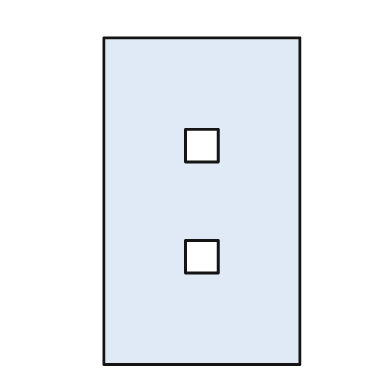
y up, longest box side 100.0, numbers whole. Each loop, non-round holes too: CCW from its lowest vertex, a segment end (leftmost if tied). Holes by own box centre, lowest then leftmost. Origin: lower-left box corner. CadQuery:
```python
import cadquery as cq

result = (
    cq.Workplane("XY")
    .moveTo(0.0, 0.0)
    .lineTo(60.0, 0.0)
    .lineTo(60.0, 100.0)
    .lineTo(0.0, 100.0)
    .close()
    .moveTo(25.0, 28.0)
    .lineTo(35.0, 28.0)
    .lineTo(35.0, 38.0)
    .lineTo(25.0, 38.0)
    .close()
    .moveTo(25.0, 62.0)
    .lineTo(35.0, 62.0)
    .lineTo(35.0, 72.0)
    .lineTo(25.0, 72.0)
    .close()
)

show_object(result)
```